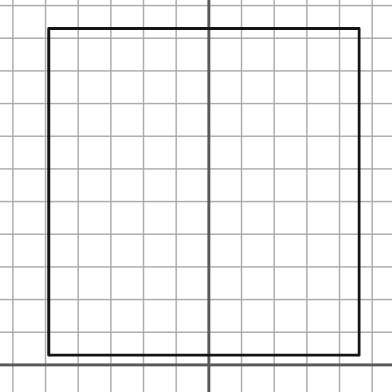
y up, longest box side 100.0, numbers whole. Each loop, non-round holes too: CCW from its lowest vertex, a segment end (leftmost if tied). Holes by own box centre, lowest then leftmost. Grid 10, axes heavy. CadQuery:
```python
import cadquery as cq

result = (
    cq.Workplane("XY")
    .moveTo(-49.0, 3.0)
    .lineTo(46.0, 3.0)
    .lineTo(46.0, 103.0)
    .lineTo(-49.0, 103.0)
    .close()
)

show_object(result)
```